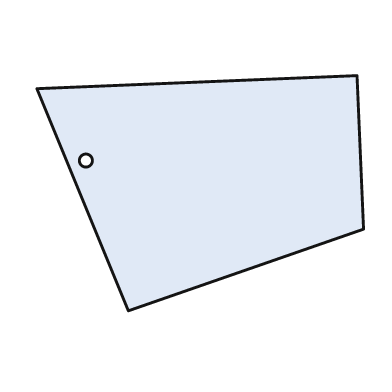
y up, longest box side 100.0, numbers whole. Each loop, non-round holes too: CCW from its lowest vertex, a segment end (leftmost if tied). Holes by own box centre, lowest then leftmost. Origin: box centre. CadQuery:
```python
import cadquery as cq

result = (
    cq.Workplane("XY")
    .moveTo(-22.0, -36.0)
    .lineTo(50.0, -11.0)
    .lineTo(48.0, 36.0)
    .lineTo(-50.0, 32.0)
    .close()
    .moveTo(-35.0, 10.0)
    .circle(2.0)
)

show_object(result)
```